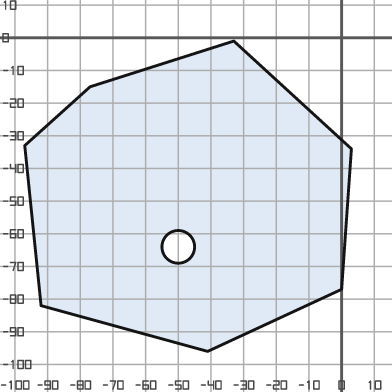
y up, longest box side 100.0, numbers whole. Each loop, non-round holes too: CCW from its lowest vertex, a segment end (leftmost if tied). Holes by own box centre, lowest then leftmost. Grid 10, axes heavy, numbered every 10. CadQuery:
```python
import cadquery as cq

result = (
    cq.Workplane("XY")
    .moveTo(-41.0, -96.0)
    .lineTo(0.0, -77.0)
    .lineTo(3.0, -34.0)
    .lineTo(-33.0, -1.0)
    .lineTo(-77.0, -15.0)
    .lineTo(-97.0, -33.0)
    .lineTo(-92.0, -82.0)
    .close()
    .moveTo(-50.0, -64.0)
    .circle(5.0)
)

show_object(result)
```